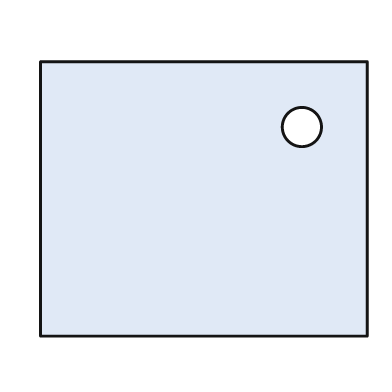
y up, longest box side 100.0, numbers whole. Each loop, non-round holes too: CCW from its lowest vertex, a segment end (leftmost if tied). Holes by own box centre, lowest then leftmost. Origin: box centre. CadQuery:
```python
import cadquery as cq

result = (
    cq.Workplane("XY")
    .moveTo(-50.0, -42.0)
    .lineTo(50.0, -42.0)
    .lineTo(50.0, 42.0)
    .lineTo(-50.0, 42.0)
    .close()
    .moveTo(30.0, 22.0)
    .circle(6.0)
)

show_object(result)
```